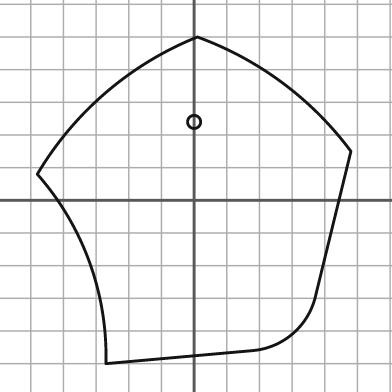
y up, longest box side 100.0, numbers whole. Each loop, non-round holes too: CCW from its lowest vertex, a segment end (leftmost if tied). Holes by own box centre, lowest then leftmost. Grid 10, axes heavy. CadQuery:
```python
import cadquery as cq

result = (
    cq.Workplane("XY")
    .moveTo(-27.0, -50.0)
    .lineTo(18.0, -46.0)
    .threePointArc((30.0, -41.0), (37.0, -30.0))
    .lineTo(48.0, 15.0)
    .threePointArc((27.0, 36.0), (1.0, 50.0))
    .threePointArc((-27.0, 33.0), (-48.0, 8.0))
    .threePointArc((-32.0, -19.0), (-27.0, -50.0))
    .close()
    .moveTo(0.0, 24.0)
    .circle(2.0)
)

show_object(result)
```